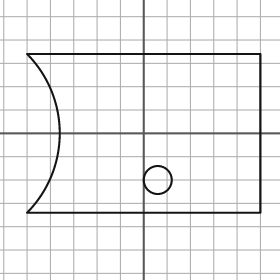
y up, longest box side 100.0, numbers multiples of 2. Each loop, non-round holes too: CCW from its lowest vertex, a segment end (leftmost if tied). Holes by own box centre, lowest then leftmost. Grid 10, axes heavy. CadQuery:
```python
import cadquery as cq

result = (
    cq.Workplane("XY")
    .moveTo(-50.0, -34.0)
    .lineTo(50.0, -34.0)
    .lineTo(50.0, 34.0)
    .lineTo(-50.0, 34.0)
    .threePointArc((-36.0, 0.0), (-50.0, -34.0))
    .close()
    .moveTo(6.0, -20.0)
    .circle(6.0)
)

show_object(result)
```